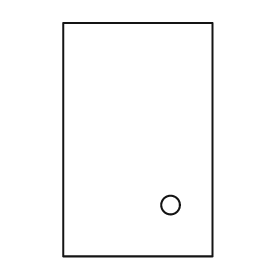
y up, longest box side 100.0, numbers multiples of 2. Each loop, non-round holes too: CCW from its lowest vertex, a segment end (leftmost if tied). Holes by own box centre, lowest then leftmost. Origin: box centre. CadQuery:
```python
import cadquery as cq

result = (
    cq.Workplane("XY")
    .moveTo(-32.0, -50.0)
    .lineTo(32.0, -50.0)
    .lineTo(32.0, 50.0)
    .lineTo(-32.0, 50.0)
    .close()
    .moveTo(14.0, -28.0)
    .circle(4.0)
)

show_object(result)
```